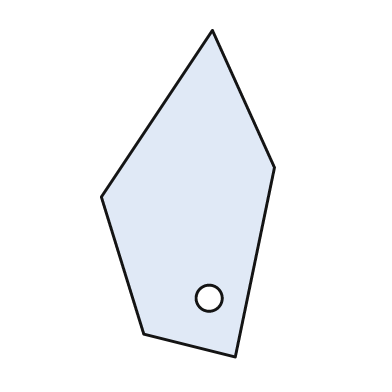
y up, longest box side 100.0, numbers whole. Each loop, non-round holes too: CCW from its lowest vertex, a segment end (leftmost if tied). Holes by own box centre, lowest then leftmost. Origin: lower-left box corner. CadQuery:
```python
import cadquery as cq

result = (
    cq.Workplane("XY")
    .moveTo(41.0, 0.0)
    .lineTo(53.0, 58.0)
    .lineTo(34.0, 100.0)
    .lineTo(0.0, 49.0)
    .lineTo(13.0, 7.0)
    .close()
    .moveTo(33.0, 18.0)
    .circle(4.0)
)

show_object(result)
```